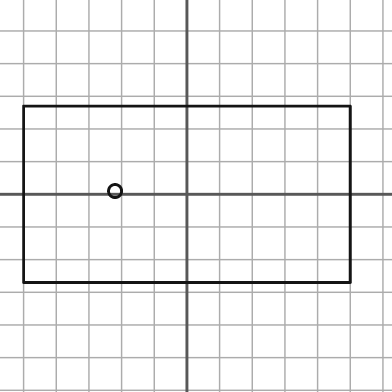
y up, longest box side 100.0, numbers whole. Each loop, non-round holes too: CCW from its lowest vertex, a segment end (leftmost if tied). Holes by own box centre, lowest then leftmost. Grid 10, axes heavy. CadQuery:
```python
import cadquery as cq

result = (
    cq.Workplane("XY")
    .moveTo(-50.0, -27.0)
    .lineTo(50.0, -27.0)
    .lineTo(50.0, 27.0)
    .lineTo(-50.0, 27.0)
    .close()
    .moveTo(-22.0, 1.0)
    .circle(2.0)
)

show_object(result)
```